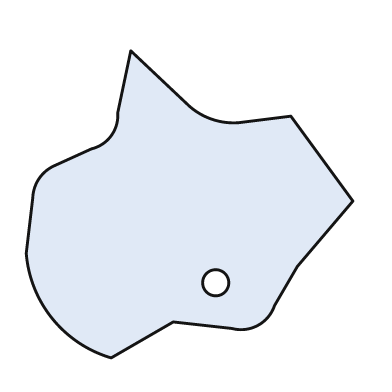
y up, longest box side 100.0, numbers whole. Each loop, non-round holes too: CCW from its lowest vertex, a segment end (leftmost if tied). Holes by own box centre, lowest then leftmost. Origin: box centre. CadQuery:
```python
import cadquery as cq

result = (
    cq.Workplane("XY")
    .moveTo(-24.0, -47.0)
    .lineTo(-5.0, -36.0)
    .lineTo(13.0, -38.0)
    .threePointArc((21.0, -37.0), (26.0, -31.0))
    .lineTo(33.0, -19.0)
    .lineTo(50.0, 1.0)
    .lineTo(31.0, 27.0)
    .lineTo(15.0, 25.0)
    .threePointArc((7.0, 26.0), (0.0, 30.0))
    .lineTo(-18.0, 47.0)
    .lineTo(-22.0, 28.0)
    .threePointArc((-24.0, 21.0), (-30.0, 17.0))
    .lineTo(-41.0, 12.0)
    .threePointArc((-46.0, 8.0), (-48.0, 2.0))
    .lineTo(-50.0, -15.0)
    .threePointArc((-42.0, -35.0), (-24.0, -47.0))
    .close()
    .moveTo(8.0, -24.0)
    .circle(4.0)
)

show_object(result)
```